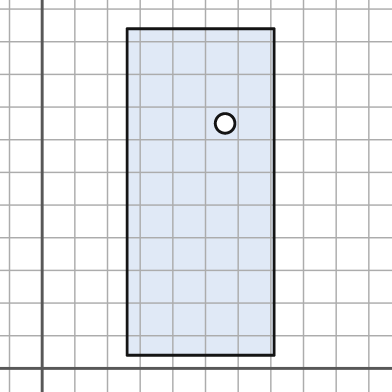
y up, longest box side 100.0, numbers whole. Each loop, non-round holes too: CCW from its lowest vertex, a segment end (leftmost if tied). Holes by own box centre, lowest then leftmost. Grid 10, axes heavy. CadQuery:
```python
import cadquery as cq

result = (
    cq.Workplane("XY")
    .moveTo(26.0, 4.0)
    .lineTo(71.0, 4.0)
    .lineTo(71.0, 104.0)
    .lineTo(26.0, 104.0)
    .close()
    .moveTo(56.0, 75.0)
    .circle(3.0)
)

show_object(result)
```